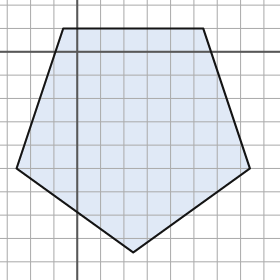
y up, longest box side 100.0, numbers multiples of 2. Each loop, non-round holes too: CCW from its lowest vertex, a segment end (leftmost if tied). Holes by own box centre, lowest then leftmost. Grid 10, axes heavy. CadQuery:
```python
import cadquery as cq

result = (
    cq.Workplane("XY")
    .moveTo(24.0, -86.0)
    .lineTo(74.0, -50.0)
    .lineTo(54.0, 10.0)
    .lineTo(-6.0, 10.0)
    .lineTo(-26.0, -50.0)
    .close()
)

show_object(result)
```